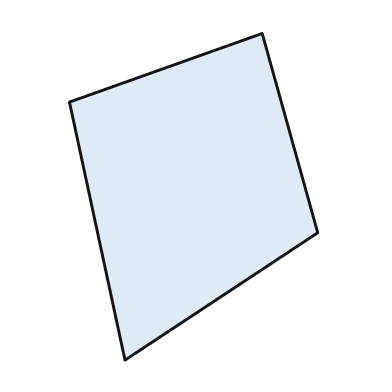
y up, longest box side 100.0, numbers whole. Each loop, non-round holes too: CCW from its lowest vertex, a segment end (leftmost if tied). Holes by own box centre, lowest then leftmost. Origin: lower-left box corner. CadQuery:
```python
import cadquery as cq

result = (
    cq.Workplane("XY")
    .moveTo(17.0, 0.0)
    .lineTo(76.0, 39.0)
    .lineTo(59.0, 100.0)
    .lineTo(0.0, 79.0)
    .close()
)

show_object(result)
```